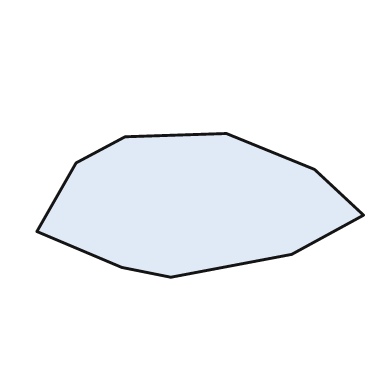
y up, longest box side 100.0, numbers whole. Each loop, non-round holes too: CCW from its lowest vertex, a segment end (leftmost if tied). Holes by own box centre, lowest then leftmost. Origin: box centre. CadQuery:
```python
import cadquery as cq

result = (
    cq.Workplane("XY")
    .moveTo(-9.0, -22.0)
    .lineTo(28.0, -15.0)
    .lineTo(50.0, -3.0)
    .lineTo(35.0, 11.0)
    .lineTo(8.0, 22.0)
    .lineTo(-23.0, 21.0)
    .lineTo(-38.0, 13.0)
    .lineTo(-50.0, -8.0)
    .lineTo(-24.0, -19.0)
    .close()
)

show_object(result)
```